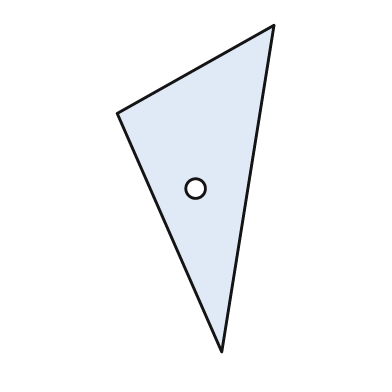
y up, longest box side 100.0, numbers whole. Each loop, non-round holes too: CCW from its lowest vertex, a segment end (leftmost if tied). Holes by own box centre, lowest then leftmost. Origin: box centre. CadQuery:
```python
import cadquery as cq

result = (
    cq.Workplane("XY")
    .moveTo(8.0, -50.0)
    .lineTo(24.0, 50.0)
    .lineTo(-24.0, 23.0)
    .close()
    .moveTo(0.0, 0.0)
    .circle(3.0)
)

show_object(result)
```